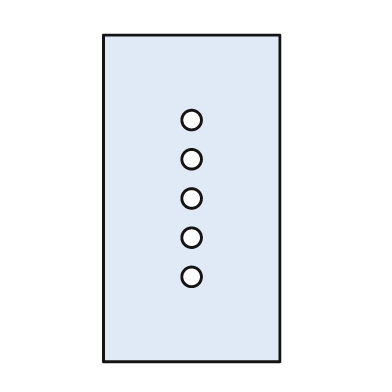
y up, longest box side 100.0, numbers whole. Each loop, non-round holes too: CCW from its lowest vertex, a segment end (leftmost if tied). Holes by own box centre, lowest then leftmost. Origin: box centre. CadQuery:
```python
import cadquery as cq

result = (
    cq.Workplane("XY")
    .moveTo(-27.0, -50.0)
    .lineTo(27.0, -50.0)
    .lineTo(27.0, 50.0)
    .lineTo(-27.0, 50.0)
    .close()
    .moveTo(0.0, -24.0)
    .circle(3.0)
    .moveTo(0.0, -12.0)
    .circle(3.0)
    .moveTo(0.0, 0.0)
    .circle(3.0)
    .moveTo(0.0, 12.0)
    .circle(3.0)
    .moveTo(0.0, 24.0)
    .circle(3.0)
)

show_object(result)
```